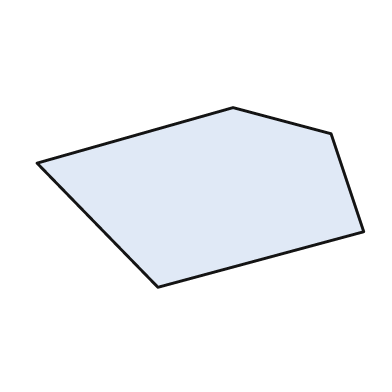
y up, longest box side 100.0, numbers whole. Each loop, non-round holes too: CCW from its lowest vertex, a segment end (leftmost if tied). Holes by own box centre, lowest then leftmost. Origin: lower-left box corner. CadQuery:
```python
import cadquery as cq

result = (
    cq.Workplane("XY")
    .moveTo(37.0, 0.0)
    .lineTo(100.0, 17.0)
    .lineTo(90.0, 47.0)
    .lineTo(60.0, 55.0)
    .lineTo(0.0, 38.0)
    .close()
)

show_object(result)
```